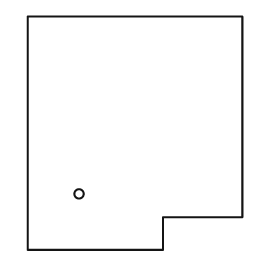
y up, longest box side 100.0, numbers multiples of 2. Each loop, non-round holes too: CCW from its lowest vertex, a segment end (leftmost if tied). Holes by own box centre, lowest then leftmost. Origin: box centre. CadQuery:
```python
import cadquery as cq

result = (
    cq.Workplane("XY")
    .moveTo(-46.0, -50.0)
    .lineTo(12.0, -50.0)
    .lineTo(12.0, -36.0)
    .lineTo(46.0, -36.0)
    .lineTo(46.0, 50.0)
    .lineTo(-46.0, 50.0)
    .close()
    .moveTo(-24.0, -26.0)
    .circle(2.0)
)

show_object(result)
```